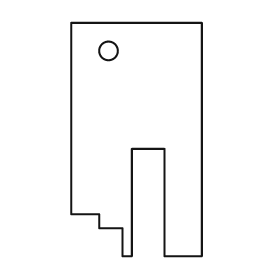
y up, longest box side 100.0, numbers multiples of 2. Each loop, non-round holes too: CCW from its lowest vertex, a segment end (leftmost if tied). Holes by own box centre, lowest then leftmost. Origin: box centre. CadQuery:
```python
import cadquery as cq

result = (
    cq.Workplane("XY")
    .moveTo(-6.0, -50.0)
    .lineTo(-2.0, -50.0)
    .lineTo(-2.0, -4.0)
    .lineTo(12.0, -4.0)
    .lineTo(12.0, -50.0)
    .lineTo(28.0, -50.0)
    .lineTo(28.0, 50.0)
    .lineTo(-28.0, 50.0)
    .lineTo(-28.0, -32.0)
    .lineTo(-16.0, -32.0)
    .lineTo(-16.0, -38.0)
    .lineTo(-6.0, -38.0)
    .close()
    .moveTo(-12.0, 38.0)
    .circle(4.0)
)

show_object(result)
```